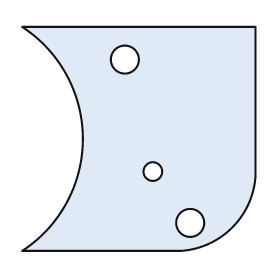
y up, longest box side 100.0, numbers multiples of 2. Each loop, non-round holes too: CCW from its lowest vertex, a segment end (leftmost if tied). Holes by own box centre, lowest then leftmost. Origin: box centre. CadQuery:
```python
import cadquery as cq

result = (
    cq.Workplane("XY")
    .moveTo(-50.0, -48.0)
    .lineTo(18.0, -48.0)
    .threePointArc((40.0, -38.0), (50.0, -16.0))
    .lineTo(50.0, 48.0)
    .lineTo(-50.0, 48.0)
    .threePointArc((-24.0, 0.0), (-50.0, -48.0))
    .close()
    .moveTo(22.0, -36.0)
    .circle(6.0)
    .moveTo(6.0, -14.0)
    .circle(4.0)
    .moveTo(-6.0, 34.0)
    .circle(6.0)
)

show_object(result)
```